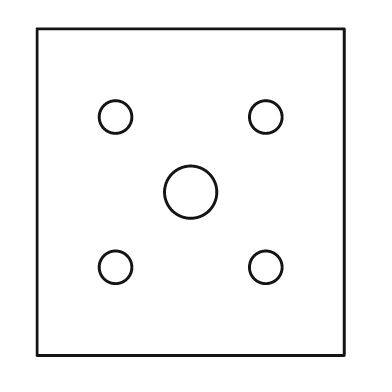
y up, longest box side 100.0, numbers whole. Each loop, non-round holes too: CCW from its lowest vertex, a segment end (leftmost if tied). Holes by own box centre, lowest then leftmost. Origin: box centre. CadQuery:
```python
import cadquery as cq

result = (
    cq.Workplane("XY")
    .moveTo(-47.0, -50.0)
    .lineTo(47.0, -50.0)
    .lineTo(47.0, 50.0)
    .lineTo(-47.0, 50.0)
    .close()
    .moveTo(-23.0, -23.0)
    .circle(5.0)
    .moveTo(23.0, -23.0)
    .circle(5.0)
    .moveTo(0.0, 0.0)
    .circle(8.0)
    .moveTo(-23.0, 23.0)
    .circle(5.0)
    .moveTo(23.0, 23.0)
    .circle(5.0)
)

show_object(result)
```